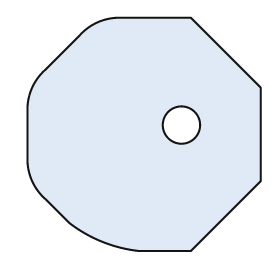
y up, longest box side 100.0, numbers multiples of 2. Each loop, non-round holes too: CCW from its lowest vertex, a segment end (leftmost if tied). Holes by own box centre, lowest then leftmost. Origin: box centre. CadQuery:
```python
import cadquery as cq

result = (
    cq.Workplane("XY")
    .moveTo(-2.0, -50.0)
    .lineTo(20.0, -50.0)
    .lineTo(50.0, -20.0)
    .lineTo(50.0, 20.0)
    .lineTo(20.0, 50.0)
    .lineTo(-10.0, 50.0)
    .threePointArc((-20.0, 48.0), (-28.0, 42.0))
    .lineTo(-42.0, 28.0)
    .threePointArc((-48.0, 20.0), (-50.0, 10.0))
    .lineTo(-50.0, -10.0)
    .threePointArc((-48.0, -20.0), (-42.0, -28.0))
    .lineTo(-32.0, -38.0)
    .threePointArc((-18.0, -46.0), (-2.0, -50.0))
    .close()
    .moveTo(16.0, 4.0)
    .circle(8.0)
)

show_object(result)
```